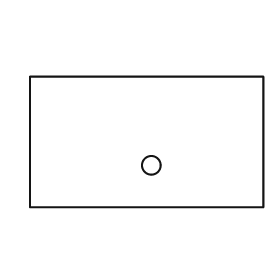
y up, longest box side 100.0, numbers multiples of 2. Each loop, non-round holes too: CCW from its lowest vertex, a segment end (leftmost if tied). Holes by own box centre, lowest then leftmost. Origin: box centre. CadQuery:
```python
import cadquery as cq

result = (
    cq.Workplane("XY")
    .moveTo(-50.0, -28.0)
    .lineTo(50.0, -28.0)
    .lineTo(50.0, 28.0)
    .lineTo(-50.0, 28.0)
    .close()
    .moveTo(2.0, -10.0)
    .circle(4.0)
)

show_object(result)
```